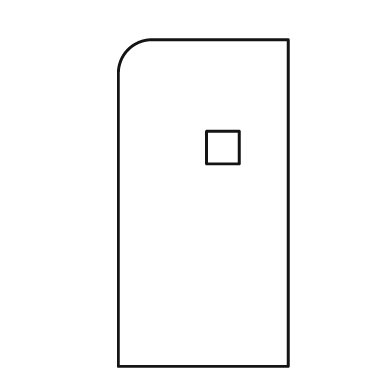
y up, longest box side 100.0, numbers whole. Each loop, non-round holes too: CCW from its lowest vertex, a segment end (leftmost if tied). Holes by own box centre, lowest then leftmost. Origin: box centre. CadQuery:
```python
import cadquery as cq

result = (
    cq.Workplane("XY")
    .moveTo(-26.0, -50.0)
    .lineTo(26.0, -50.0)
    .lineTo(26.0, 50.0)
    .lineTo(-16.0, 50.0)
    .threePointArc((-23.0, 47.0), (-26.0, 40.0))
    .close()
    .moveTo(1.0, 12.0)
    .lineTo(11.0, 12.0)
    .lineTo(11.0, 22.0)
    .lineTo(1.0, 22.0)
    .close()
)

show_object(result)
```